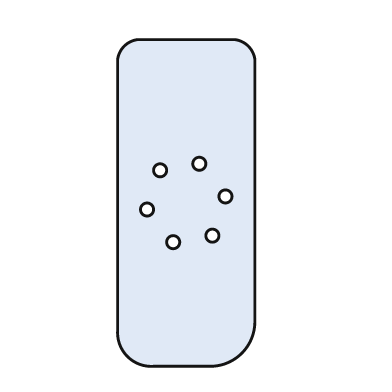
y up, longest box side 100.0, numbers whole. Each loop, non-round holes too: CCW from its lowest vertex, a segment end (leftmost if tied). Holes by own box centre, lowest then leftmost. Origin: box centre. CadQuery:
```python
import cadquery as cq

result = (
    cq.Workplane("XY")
    .moveTo(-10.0, -50.0)
    .lineTo(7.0, -50.0)
    .threePointArc((17.0, -46.0), (21.0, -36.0))
    .lineTo(21.0, 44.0)
    .threePointArc((19.0, 48.0), (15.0, 50.0))
    .lineTo(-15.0, 50.0)
    .threePointArc((-19.0, 48.0), (-21.0, 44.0))
    .lineTo(-21.0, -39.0)
    .threePointArc((-18.0, -47.0), (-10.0, -50.0))
    .close()
    .moveTo(-4.0, -12.0)
    .circle(2.0)
    .moveTo(8.0, -10.0)
    .circle(2.0)
    .moveTo(-12.0, -2.0)
    .circle(2.0)
    .moveTo(12.0, 2.0)
    .circle(2.0)
    .moveTo(-8.0, 10.0)
    .circle(2.0)
    .moveTo(4.0, 12.0)
    .circle(2.0)
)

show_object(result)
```